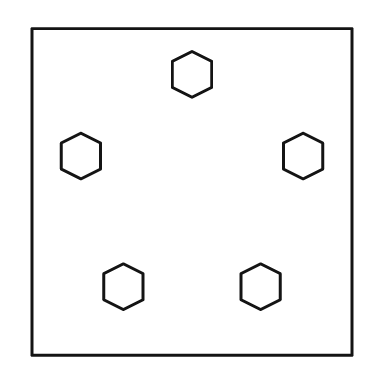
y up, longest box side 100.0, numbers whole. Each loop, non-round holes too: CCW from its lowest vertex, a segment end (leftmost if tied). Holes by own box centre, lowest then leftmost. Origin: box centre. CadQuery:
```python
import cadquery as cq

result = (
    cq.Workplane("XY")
    .moveTo(-49.0, -50.0)
    .lineTo(49.0, -50.0)
    .lineTo(49.0, 50.0)
    .lineTo(-49.0, 50.0)
    .close()
    .moveTo(-21.0, -36.0)
    .lineTo(-15.0, -33.0)
    .lineTo(-15.0, -25.0)
    .lineTo(-21.0, -22.0)
    .lineTo(-27.0, -25.0)
    .lineTo(-27.0, -33.0)
    .close()
    .moveTo(21.0, -36.0)
    .lineTo(27.0, -33.0)
    .lineTo(27.0, -25.0)
    .lineTo(21.0, -22.0)
    .lineTo(15.0, -25.0)
    .lineTo(15.0, -33.0)
    .close()
    .moveTo(-34.0, 4.0)
    .lineTo(-28.0, 7.0)
    .lineTo(-28.0, 15.0)
    .lineTo(-34.0, 18.0)
    .lineTo(-40.0, 15.0)
    .lineTo(-40.0, 7.0)
    .close()
    .moveTo(34.0, 4.0)
    .lineTo(40.0, 7.0)
    .lineTo(40.0, 15.0)
    .lineTo(34.0, 18.0)
    .lineTo(28.0, 15.0)
    .lineTo(28.0, 7.0)
    .close()
    .moveTo(0.0, 29.0)
    .lineTo(6.0, 32.0)
    .lineTo(6.0, 40.0)
    .lineTo(0.0, 43.0)
    .lineTo(-6.0, 40.0)
    .lineTo(-6.0, 32.0)
    .close()
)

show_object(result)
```